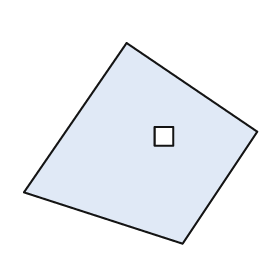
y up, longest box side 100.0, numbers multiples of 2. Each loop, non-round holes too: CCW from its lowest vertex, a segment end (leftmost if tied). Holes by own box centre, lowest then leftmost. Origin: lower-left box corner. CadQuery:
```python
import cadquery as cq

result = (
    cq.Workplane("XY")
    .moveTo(68.0, 0.0)
    .lineTo(100.0, 48.0)
    .lineTo(44.0, 86.0)
    .lineTo(0.0, 22.0)
    .close()
    .moveTo(56.0, 42.0)
    .lineTo(64.0, 42.0)
    .lineTo(64.0, 50.0)
    .lineTo(56.0, 50.0)
    .close()
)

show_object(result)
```